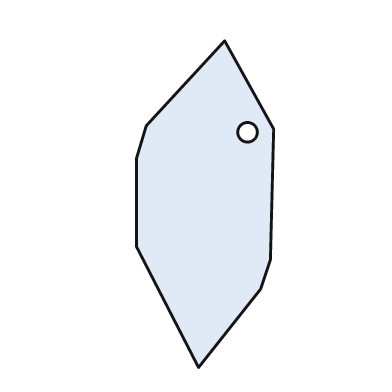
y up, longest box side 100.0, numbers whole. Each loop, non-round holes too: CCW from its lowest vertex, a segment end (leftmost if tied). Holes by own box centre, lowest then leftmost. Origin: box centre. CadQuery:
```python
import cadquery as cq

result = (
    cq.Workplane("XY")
    .moveTo(-2.0, -50.0)
    .lineTo(17.0, -26.0)
    .lineTo(20.0, -17.0)
    .lineTo(21.0, 23.0)
    .lineTo(6.0, 50.0)
    .lineTo(-18.0, 24.0)
    .lineTo(-21.0, 14.0)
    .lineTo(-21.0, -13.0)
    .close()
    .moveTo(13.0, 22.0)
    .circle(3.0)
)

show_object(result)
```